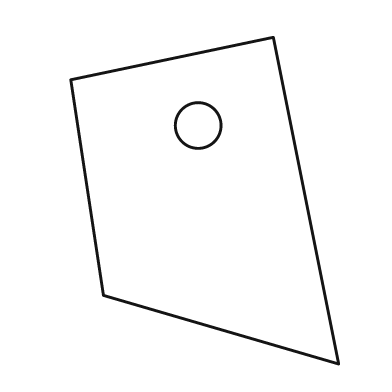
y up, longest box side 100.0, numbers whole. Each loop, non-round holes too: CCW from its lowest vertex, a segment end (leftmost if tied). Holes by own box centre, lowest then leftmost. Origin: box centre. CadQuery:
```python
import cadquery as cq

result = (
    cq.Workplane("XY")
    .moveTo(41.0, -50.0)
    .lineTo(21.0, 50.0)
    .lineTo(-41.0, 37.0)
    .lineTo(-31.0, -29.0)
    .close()
    .moveTo(-2.0, 23.0)
    .circle(7.0)
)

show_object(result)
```